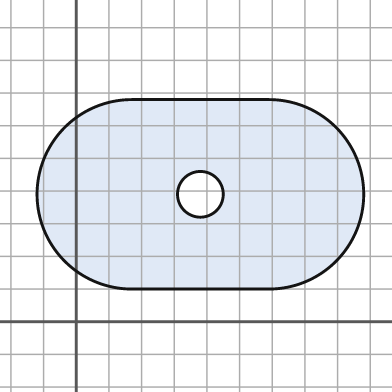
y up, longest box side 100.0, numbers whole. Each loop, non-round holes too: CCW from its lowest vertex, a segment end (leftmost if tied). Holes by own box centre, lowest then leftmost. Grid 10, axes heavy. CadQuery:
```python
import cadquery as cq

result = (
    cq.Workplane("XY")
    .moveTo(17.0, 10.0)
    .lineTo(59.0, 10.0)
    .threePointArc((88.0, 39.0), (59.0, 68.0))
    .lineTo(17.0, 68.0)
    .threePointArc((-12.0, 39.0), (17.0, 10.0))
    .close()
    .moveTo(38.0, 39.0)
    .circle(7.0)
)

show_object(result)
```